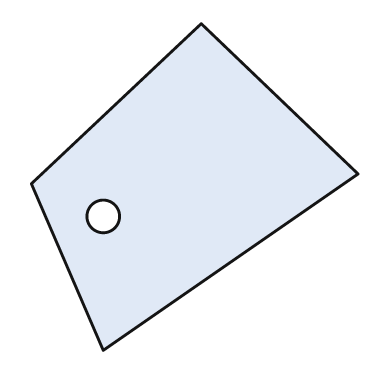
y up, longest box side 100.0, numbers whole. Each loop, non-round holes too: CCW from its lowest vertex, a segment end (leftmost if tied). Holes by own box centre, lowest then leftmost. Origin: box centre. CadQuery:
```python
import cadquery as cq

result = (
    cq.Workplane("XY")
    .moveTo(-28.0, -50.0)
    .lineTo(50.0, 4.0)
    .lineTo(2.0, 50.0)
    .lineTo(-50.0, 1.0)
    .close()
    .moveTo(-28.0, -9.0)
    .circle(5.0)
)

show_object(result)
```